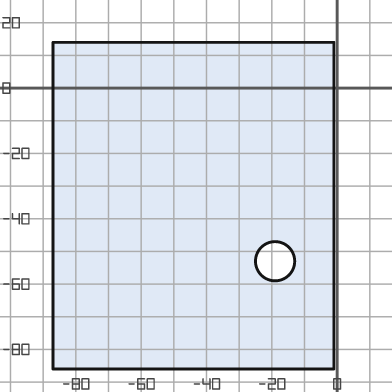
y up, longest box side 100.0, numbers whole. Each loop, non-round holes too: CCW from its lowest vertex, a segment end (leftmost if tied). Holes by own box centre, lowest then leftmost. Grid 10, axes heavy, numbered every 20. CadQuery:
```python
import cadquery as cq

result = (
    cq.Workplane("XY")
    .moveTo(-87.0, -86.0)
    .lineTo(-1.0, -86.0)
    .lineTo(-1.0, 14.0)
    .lineTo(-87.0, 14.0)
    .close()
    .moveTo(-19.0, -53.0)
    .circle(6.0)
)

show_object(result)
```